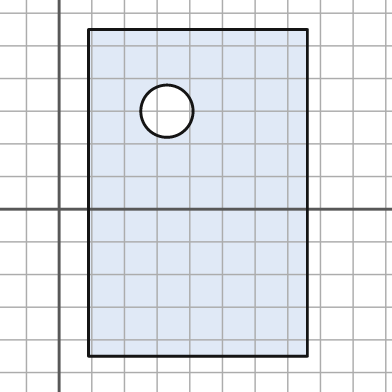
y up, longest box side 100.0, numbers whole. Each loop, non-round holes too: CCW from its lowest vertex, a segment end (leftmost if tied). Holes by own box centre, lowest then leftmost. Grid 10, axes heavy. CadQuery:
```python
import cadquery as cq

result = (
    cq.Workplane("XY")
    .moveTo(9.0, -45.0)
    .lineTo(76.0, -45.0)
    .lineTo(76.0, 55.0)
    .lineTo(9.0, 55.0)
    .close()
    .moveTo(33.0, 30.0)
    .circle(8.0)
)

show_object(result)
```